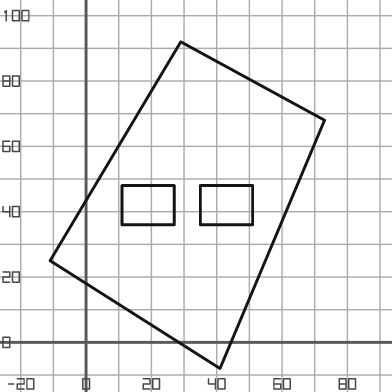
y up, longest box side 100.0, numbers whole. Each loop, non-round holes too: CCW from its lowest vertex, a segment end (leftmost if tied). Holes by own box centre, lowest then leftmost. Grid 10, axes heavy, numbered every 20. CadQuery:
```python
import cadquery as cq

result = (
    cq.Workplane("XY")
    .moveTo(41.0, -8.0)
    .lineTo(73.0, 68.0)
    .lineTo(29.0, 92.0)
    .lineTo(-11.0, 25.0)
    .close()
    .moveTo(11.0, 36.0)
    .lineTo(27.0, 36.0)
    .lineTo(27.0, 48.0)
    .lineTo(11.0, 48.0)
    .close()
    .moveTo(35.0, 36.0)
    .lineTo(51.0, 36.0)
    .lineTo(51.0, 48.0)
    .lineTo(35.0, 48.0)
    .close()
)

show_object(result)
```